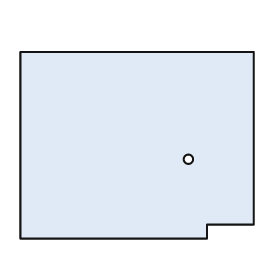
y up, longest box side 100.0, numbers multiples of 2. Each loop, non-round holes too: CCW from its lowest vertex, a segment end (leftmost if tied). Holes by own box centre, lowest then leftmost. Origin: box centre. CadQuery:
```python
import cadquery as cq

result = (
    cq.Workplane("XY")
    .moveTo(-50.0, -40.0)
    .lineTo(30.0, -40.0)
    .lineTo(30.0, -34.0)
    .lineTo(50.0, -34.0)
    .lineTo(50.0, 40.0)
    .lineTo(-50.0, 40.0)
    .close()
    .moveTo(22.0, -6.0)
    .circle(2.0)
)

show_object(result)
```